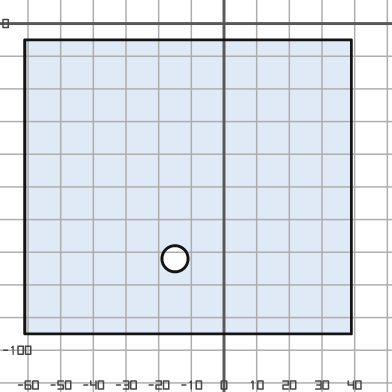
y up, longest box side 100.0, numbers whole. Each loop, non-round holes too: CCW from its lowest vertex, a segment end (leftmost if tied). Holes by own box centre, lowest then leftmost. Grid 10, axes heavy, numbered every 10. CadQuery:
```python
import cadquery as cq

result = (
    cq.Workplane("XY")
    .moveTo(-61.0, -95.0)
    .lineTo(39.0, -95.0)
    .lineTo(39.0, -5.0)
    .lineTo(-61.0, -5.0)
    .close()
    .moveTo(-15.0, -72.0)
    .circle(4.0)
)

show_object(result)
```